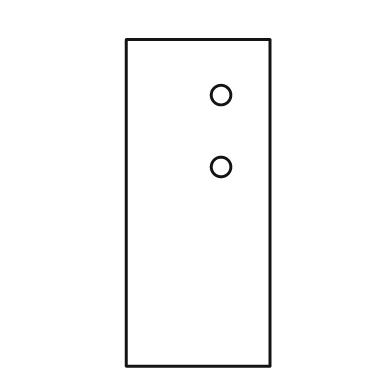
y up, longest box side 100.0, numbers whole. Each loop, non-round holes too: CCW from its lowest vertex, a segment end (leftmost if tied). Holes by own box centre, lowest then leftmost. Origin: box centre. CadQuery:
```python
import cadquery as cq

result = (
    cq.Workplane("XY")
    .moveTo(-22.0, -50.0)
    .lineTo(22.0, -50.0)
    .lineTo(22.0, 50.0)
    .lineTo(-22.0, 50.0)
    .close()
    .moveTo(7.0, 11.0)
    .circle(3.0)
    .moveTo(7.0, 33.0)
    .circle(3.0)
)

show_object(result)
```